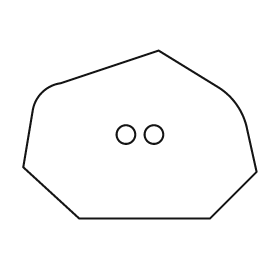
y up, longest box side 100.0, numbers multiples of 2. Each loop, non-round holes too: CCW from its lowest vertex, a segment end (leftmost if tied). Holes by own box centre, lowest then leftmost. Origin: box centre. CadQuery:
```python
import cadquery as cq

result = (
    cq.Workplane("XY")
    .moveTo(-26.0, -36.0)
    .lineTo(30.0, -36.0)
    .lineTo(50.0, -16.0)
    .lineTo(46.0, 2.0)
    .threePointArc((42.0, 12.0), (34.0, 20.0))
    .lineTo(8.0, 36.0)
    .lineTo(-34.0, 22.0)
    .threePointArc((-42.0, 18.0), (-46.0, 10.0))
    .lineTo(-50.0, -14.0)
    .close()
    .moveTo(-6.0, 0.0)
    .circle(4.0)
    .moveTo(6.0, 0.0)
    .circle(4.0)
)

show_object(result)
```